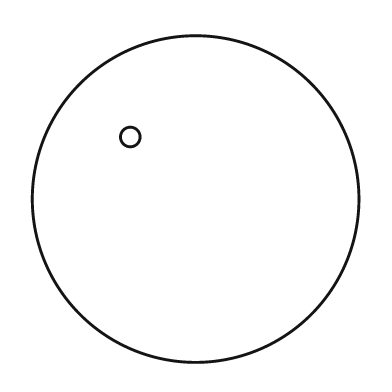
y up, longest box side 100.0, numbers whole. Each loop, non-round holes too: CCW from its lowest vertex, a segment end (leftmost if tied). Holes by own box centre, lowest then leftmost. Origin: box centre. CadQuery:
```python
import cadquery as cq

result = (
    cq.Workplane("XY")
    .moveTo(0.0, 0.0)
    .circle(50.0)
    .moveTo(-20.0, 19.0)
    .circle(3.0)
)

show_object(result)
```